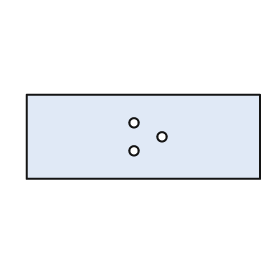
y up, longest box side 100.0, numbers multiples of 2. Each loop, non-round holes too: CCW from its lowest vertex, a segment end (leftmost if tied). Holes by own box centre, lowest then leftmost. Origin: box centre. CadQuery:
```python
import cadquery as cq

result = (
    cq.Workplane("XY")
    .moveTo(-50.0, -18.0)
    .lineTo(50.0, -18.0)
    .lineTo(50.0, 18.0)
    .lineTo(-50.0, 18.0)
    .close()
    .moveTo(-4.0, -6.0)
    .circle(2.0)
    .moveTo(8.0, 0.0)
    .circle(2.0)
    .moveTo(-4.0, 6.0)
    .circle(2.0)
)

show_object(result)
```